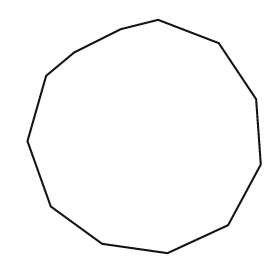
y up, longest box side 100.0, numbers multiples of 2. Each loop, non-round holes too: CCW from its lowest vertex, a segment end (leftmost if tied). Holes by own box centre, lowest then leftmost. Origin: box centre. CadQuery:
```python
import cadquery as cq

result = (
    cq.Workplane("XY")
    .moveTo(10.0, -50.0)
    .lineTo(36.0, -38.0)
    .lineTo(50.0, -12.0)
    .lineTo(48.0, 16.0)
    .lineTo(32.0, 40.0)
    .lineTo(6.0, 50.0)
    .lineTo(-10.0, 46.0)
    .lineTo(-30.0, 36.0)
    .lineTo(-42.0, 26.0)
    .lineTo(-50.0, -2.0)
    .lineTo(-40.0, -30.0)
    .lineTo(-18.0, -46.0)
    .close()
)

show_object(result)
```